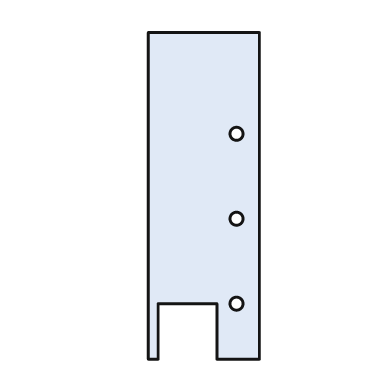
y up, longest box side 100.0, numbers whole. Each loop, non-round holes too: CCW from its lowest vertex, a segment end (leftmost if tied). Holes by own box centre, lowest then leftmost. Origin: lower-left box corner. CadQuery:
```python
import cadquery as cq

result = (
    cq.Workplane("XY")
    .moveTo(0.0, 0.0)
    .lineTo(3.0, 0.0)
    .lineTo(3.0, 17.0)
    .lineTo(21.0, 17.0)
    .lineTo(21.0, 0.0)
    .lineTo(34.0, 0.0)
    .lineTo(34.0, 100.0)
    .lineTo(0.0, 100.0)
    .close()
    .moveTo(27.0, 17.0)
    .circle(2.0)
    .moveTo(27.0, 43.0)
    .circle(2.0)
    .moveTo(27.0, 69.0)
    .circle(2.0)
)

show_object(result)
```